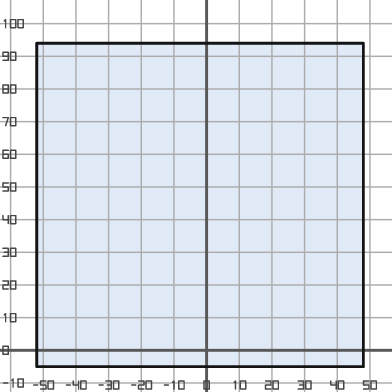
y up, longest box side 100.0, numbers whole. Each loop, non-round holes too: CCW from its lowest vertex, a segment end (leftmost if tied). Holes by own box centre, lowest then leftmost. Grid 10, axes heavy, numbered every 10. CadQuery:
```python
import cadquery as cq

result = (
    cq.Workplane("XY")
    .moveTo(-52.0, -5.0)
    .lineTo(48.0, -5.0)
    .lineTo(48.0, 94.0)
    .lineTo(-52.0, 94.0)
    .close()
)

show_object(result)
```